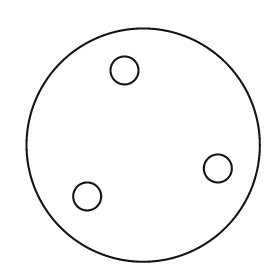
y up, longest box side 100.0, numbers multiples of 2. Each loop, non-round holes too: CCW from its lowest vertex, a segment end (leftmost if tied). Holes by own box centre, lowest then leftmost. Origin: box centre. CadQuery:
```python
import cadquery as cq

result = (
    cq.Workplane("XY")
    .moveTo(0.0, 0.0)
    .circle(50.0)
    .moveTo(-24.0, -22.0)
    .circle(6.0)
    .moveTo(32.0, -10.0)
    .circle(6.0)
    .moveTo(-8.0, 32.0)
    .circle(6.0)
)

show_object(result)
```